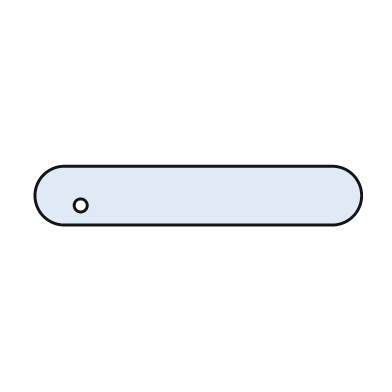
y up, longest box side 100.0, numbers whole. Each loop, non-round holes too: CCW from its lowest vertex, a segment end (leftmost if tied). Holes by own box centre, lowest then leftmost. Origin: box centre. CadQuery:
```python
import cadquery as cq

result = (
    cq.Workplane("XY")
    .moveTo(-41.0, -9.0)
    .lineTo(41.0, -9.0)
    .threePointArc((50.0, 0.0), (41.0, 9.0))
    .lineTo(-41.0, 9.0)
    .threePointArc((-50.0, 0.0), (-41.0, -9.0))
    .close()
    .moveTo(-36.0, -3.0)
    .circle(2.0)
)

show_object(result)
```